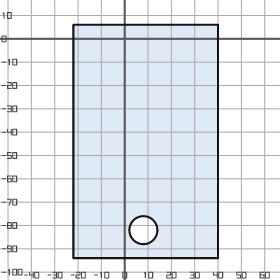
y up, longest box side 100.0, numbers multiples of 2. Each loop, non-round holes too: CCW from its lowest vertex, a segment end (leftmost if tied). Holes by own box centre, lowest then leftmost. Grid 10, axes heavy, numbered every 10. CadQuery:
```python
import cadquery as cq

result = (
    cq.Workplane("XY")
    .moveTo(-22.0, -94.0)
    .lineTo(40.0, -94.0)
    .lineTo(40.0, 6.0)
    .lineTo(-22.0, 6.0)
    .close()
    .moveTo(8.0, -82.0)
    .circle(6.0)
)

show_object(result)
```